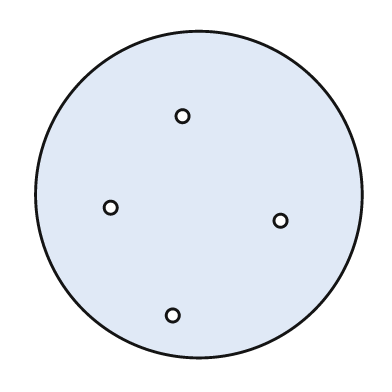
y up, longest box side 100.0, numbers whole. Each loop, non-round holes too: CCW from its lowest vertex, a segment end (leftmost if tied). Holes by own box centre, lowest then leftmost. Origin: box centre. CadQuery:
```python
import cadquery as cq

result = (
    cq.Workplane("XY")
    .moveTo(0.0, 0.0)
    .circle(50.0)
    .moveTo(-8.0, -37.0)
    .circle(2.0)
    .moveTo(25.0, -8.0)
    .circle(2.0)
    .moveTo(-27.0, -4.0)
    .circle(2.0)
    .moveTo(-5.0, 24.0)
    .circle(2.0)
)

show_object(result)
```